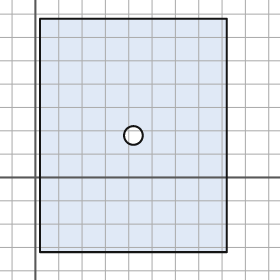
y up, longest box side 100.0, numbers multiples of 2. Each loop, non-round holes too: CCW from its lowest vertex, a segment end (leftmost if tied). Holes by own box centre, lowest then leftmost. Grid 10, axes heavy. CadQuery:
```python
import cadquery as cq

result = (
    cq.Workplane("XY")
    .moveTo(2.0, -32.0)
    .lineTo(82.0, -32.0)
    .lineTo(82.0, 68.0)
    .lineTo(2.0, 68.0)
    .close()
    .moveTo(42.0, 18.0)
    .circle(4.0)
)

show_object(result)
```